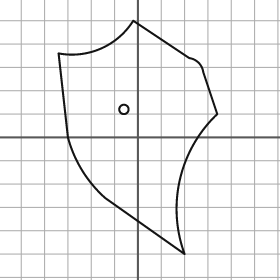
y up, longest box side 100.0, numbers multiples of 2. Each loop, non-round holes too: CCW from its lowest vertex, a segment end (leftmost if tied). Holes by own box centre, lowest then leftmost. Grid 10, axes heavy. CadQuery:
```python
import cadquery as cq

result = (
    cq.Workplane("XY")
    .moveTo(20.0, -50.0)
    .threePointArc((18.0, -18.0), (34.0, 10.0))
    .lineTo(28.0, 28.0)
    .threePointArc((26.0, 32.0), (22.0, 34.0))
    .lineTo(-2.0, 50.0)
    .threePointArc((-16.0, 38.0), (-34.0, 36.0))
    .lineTo(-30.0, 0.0)
    .threePointArc((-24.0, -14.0), (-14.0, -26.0))
    .close()
    .moveTo(-6.0, 12.0)
    .circle(2.0)
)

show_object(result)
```